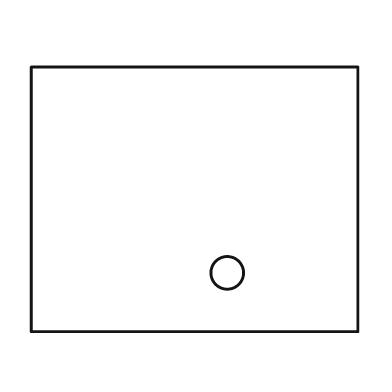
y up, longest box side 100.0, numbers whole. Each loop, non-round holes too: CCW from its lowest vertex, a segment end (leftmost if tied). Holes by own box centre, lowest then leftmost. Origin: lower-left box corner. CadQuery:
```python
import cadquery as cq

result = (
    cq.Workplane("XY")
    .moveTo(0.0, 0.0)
    .lineTo(100.0, 0.0)
    .lineTo(100.0, 81.0)
    .lineTo(0.0, 81.0)
    .close()
    .moveTo(60.0, 18.0)
    .circle(5.0)
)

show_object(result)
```